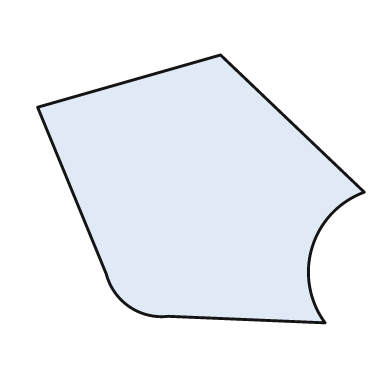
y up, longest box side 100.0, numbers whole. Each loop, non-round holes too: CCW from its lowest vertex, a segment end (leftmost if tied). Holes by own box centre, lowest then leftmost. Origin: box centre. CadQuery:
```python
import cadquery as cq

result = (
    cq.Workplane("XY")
    .moveTo(38.0, -41.0)
    .threePointArc((34.0, -18.0), (50.0, -1.0))
    .lineTo(6.0, 41.0)
    .lineTo(-50.0, 25.0)
    .lineTo(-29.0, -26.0)
    .threePointArc((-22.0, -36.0), (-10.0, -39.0))
    .close()
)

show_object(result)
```